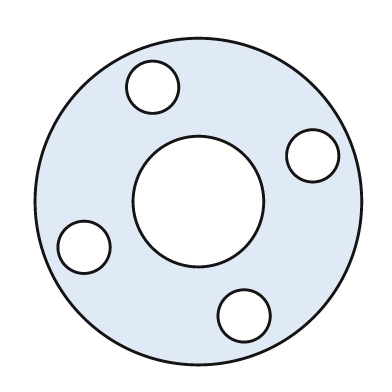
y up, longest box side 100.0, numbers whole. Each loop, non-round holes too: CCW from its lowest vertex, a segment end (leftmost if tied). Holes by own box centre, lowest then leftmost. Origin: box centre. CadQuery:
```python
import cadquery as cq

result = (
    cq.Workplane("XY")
    .moveTo(0.0, 0.0)
    .circle(50.0)
    .moveTo(14.0, -35.0)
    .circle(8.0)
    .moveTo(-35.0, -14.0)
    .circle(8.0)
    .moveTo(0.0, 0.0)
    .circle(20.0)
    .moveTo(35.0, 14.0)
    .circle(8.0)
    .moveTo(-14.0, 35.0)
    .circle(8.0)
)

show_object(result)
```